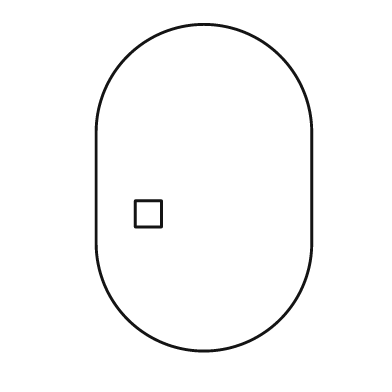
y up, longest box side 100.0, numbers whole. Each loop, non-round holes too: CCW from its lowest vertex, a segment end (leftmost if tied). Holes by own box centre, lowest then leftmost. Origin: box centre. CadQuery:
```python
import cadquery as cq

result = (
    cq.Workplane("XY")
    .moveTo(-33.0, -17.0)
    .threePointArc((0.0, -50.0), (33.0, -17.0))
    .lineTo(33.0, 17.0)
    .threePointArc((0.0, 50.0), (-33.0, 17.0))
    .close()
    .moveTo(-21.0, -12.0)
    .lineTo(-13.0, -12.0)
    .lineTo(-13.0, -4.0)
    .lineTo(-21.0, -4.0)
    .close()
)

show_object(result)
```